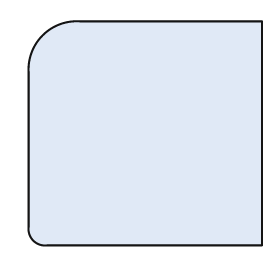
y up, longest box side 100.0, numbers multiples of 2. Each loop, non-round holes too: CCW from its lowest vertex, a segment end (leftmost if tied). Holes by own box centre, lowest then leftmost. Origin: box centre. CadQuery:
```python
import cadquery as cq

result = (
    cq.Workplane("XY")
    .moveTo(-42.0, -48.0)
    .lineTo(50.0, -48.0)
    .lineTo(50.0, 48.0)
    .lineTo(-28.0, 48.0)
    .threePointArc((-44.0, 42.0), (-50.0, 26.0))
    .lineTo(-50.0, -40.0)
    .threePointArc((-48.0, -46.0), (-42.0, -48.0))
    .close()
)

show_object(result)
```